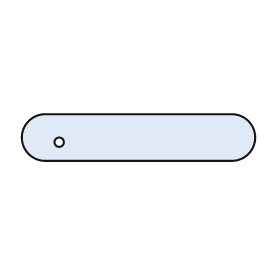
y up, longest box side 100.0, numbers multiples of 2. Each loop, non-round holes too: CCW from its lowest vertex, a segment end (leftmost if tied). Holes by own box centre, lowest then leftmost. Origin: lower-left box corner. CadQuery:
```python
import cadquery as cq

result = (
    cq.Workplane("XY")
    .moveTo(10.0, 0.0)
    .lineTo(90.0, 0.0)
    .threePointArc((100.0, 10.0), (90.0, 20.0))
    .lineTo(10.0, 20.0)
    .threePointArc((0.0, 10.0), (10.0, 0.0))
    .close()
    .moveTo(16.0, 8.0)
    .circle(2.0)
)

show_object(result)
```